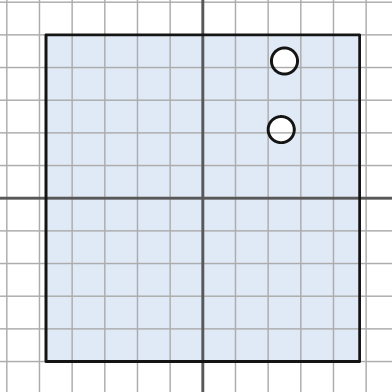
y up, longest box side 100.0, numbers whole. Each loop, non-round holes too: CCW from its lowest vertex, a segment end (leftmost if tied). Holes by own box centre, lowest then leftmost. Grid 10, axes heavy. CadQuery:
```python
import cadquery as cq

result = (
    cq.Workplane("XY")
    .moveTo(-48.0, -50.0)
    .lineTo(48.0, -50.0)
    .lineTo(48.0, 50.0)
    .lineTo(-48.0, 50.0)
    .close()
    .moveTo(24.0, 21.0)
    .circle(4.0)
    .moveTo(25.0, 42.0)
    .circle(4.0)
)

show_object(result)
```